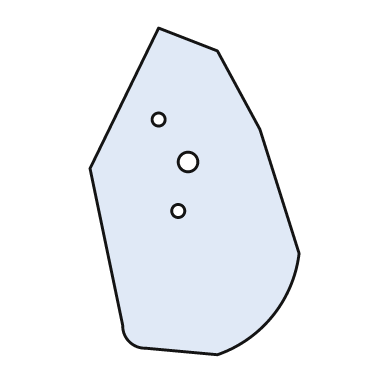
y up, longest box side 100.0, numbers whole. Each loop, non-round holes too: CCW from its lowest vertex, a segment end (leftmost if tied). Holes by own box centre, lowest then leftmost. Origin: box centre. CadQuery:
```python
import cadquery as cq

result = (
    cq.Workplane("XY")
    .moveTo(7.0, -50.0)
    .threePointArc((24.0, -38.0), (32.0, -19.0))
    .lineTo(20.0, 19.0)
    .lineTo(7.0, 43.0)
    .lineTo(-11.0, 50.0)
    .lineTo(-32.0, 7.0)
    .lineTo(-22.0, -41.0)
    .threePointArc((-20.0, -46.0), (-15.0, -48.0))
    .close()
    .moveTo(-5.0, -6.0)
    .circle(2.0)
    .moveTo(-2.0, 9.0)
    .circle(3.0)
    .moveTo(-11.0, 22.0)
    .circle(2.0)
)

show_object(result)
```